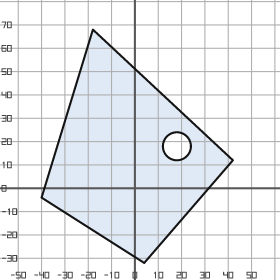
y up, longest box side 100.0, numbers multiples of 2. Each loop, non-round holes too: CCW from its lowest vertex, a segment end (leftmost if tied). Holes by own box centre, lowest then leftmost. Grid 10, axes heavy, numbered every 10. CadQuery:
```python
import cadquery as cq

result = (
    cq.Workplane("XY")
    .moveTo(4.0, -32.0)
    .lineTo(42.0, 12.0)
    .lineTo(-18.0, 68.0)
    .lineTo(-40.0, -4.0)
    .close()
    .moveTo(18.0, 18.0)
    .circle(6.0)
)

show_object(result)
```